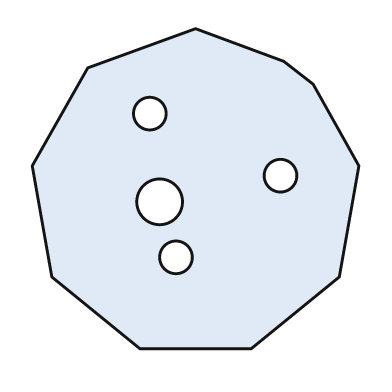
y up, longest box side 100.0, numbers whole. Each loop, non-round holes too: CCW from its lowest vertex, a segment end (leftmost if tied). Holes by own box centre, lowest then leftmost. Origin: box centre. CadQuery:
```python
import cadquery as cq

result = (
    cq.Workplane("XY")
    .moveTo(-17.0, -49.0)
    .lineTo(17.0, -49.0)
    .lineTo(44.0, -27.0)
    .lineTo(50.0, 7.0)
    .lineTo(36.0, 32.0)
    .lineTo(27.0, 39.0)
    .lineTo(0.0, 49.0)
    .lineTo(-33.0, 37.0)
    .lineTo(-50.0, 7.0)
    .lineTo(-44.0, -27.0)
    .close()
    .moveTo(-6.0, -21.0)
    .circle(5.0)
    .moveTo(-11.0, -4.0)
    .circle(7.0)
    .moveTo(26.0, 4.0)
    .circle(5.0)
    .moveTo(-14.0, 23.0)
    .circle(5.0)
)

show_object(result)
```